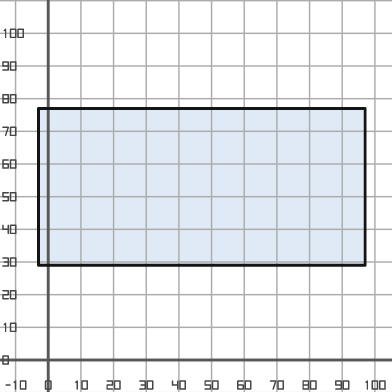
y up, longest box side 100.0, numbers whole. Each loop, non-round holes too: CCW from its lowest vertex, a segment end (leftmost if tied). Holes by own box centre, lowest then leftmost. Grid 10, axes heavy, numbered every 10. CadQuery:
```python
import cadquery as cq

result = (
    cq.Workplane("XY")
    .moveTo(-3.0, 29.0)
    .lineTo(97.0, 29.0)
    .lineTo(97.0, 77.0)
    .lineTo(-3.0, 77.0)
    .close()
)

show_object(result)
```